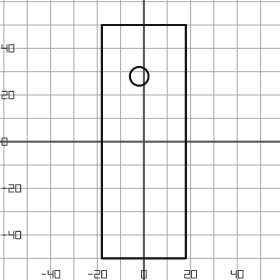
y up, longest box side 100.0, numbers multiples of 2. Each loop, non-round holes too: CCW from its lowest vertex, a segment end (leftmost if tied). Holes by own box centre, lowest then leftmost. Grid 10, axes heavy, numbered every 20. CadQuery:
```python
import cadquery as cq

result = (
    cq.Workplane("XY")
    .moveTo(-18.0, -50.0)
    .lineTo(18.0, -50.0)
    .lineTo(18.0, 50.0)
    .lineTo(-18.0, 50.0)
    .close()
    .moveTo(-2.0, 28.0)
    .circle(4.0)
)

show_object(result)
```